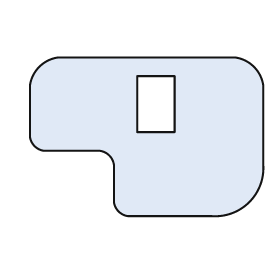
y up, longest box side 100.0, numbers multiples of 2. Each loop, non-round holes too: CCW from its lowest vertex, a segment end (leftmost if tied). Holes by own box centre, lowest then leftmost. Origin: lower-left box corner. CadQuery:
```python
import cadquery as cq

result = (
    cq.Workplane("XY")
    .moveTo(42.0, 0.0)
    .lineTo(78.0, 0.0)
    .threePointArc((94.0, 6.0), (100.0, 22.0))
    .lineTo(100.0, 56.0)
    .threePointArc((96.0, 64.0), (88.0, 68.0))
    .lineTo(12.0, 68.0)
    .threePointArc((4.0, 64.0), (0.0, 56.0))
    .lineTo(0.0, 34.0)
    .threePointArc((2.0, 30.0), (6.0, 28.0))
    .lineTo(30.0, 28.0)
    .threePointArc((34.0, 26.0), (36.0, 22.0))
    .lineTo(36.0, 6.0)
    .threePointArc((38.0, 2.0), (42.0, 0.0))
    .close()
    .moveTo(46.0, 36.0)
    .lineTo(62.0, 36.0)
    .lineTo(62.0, 60.0)
    .lineTo(46.0, 60.0)
    .close()
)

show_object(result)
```